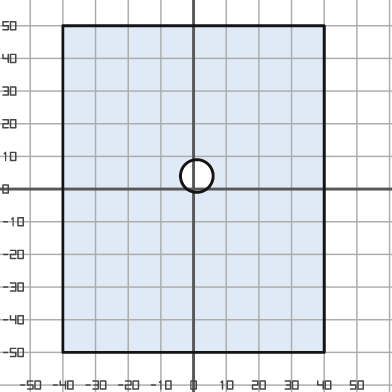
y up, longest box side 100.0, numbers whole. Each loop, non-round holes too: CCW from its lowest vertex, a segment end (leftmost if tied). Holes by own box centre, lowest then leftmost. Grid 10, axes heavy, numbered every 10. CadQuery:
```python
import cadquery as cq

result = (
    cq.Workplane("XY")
    .moveTo(-40.0, -50.0)
    .lineTo(40.0, -50.0)
    .lineTo(40.0, 50.0)
    .lineTo(-40.0, 50.0)
    .close()
    .moveTo(1.0, 4.0)
    .circle(5.0)
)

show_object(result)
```